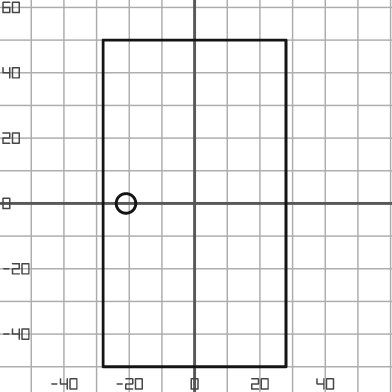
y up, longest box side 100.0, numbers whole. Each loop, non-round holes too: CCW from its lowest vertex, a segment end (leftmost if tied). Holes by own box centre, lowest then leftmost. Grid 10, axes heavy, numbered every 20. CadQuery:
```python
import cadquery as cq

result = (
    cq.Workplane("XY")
    .moveTo(-28.0, -50.0)
    .lineTo(28.0, -50.0)
    .lineTo(28.0, 50.0)
    .lineTo(-28.0, 50.0)
    .close()
    .moveTo(-21.0, 0.0)
    .circle(3.0)
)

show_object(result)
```